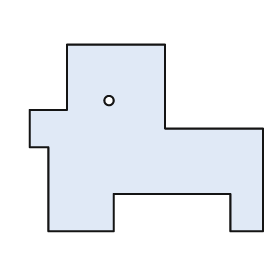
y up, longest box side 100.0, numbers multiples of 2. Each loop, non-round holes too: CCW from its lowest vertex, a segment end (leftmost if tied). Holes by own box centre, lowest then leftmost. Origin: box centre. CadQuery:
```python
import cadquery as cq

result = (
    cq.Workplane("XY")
    .moveTo(-42.0, -40.0)
    .lineTo(-14.0, -40.0)
    .lineTo(-14.0, -24.0)
    .lineTo(36.0, -24.0)
    .lineTo(36.0, -40.0)
    .lineTo(50.0, -40.0)
    .lineTo(50.0, 4.0)
    .lineTo(8.0, 4.0)
    .lineTo(8.0, 40.0)
    .lineTo(-34.0, 40.0)
    .lineTo(-34.0, 12.0)
    .lineTo(-50.0, 12.0)
    .lineTo(-50.0, -4.0)
    .lineTo(-42.0, -4.0)
    .close()
    .moveTo(-16.0, 16.0)
    .circle(2.0)
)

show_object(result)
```